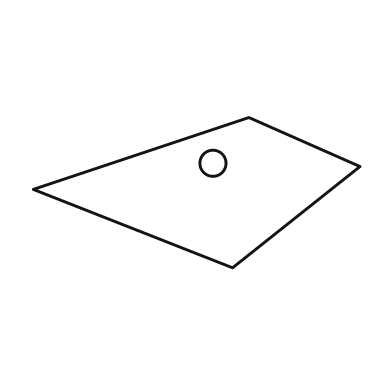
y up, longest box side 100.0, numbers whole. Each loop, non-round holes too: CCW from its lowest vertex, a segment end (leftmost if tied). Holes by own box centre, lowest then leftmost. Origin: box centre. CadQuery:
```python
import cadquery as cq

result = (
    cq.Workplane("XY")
    .moveTo(11.0, -23.0)
    .lineTo(50.0, 8.0)
    .lineTo(16.0, 23.0)
    .lineTo(-50.0, 1.0)
    .close()
    .moveTo(5.0, 9.0)
    .circle(4.0)
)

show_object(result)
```